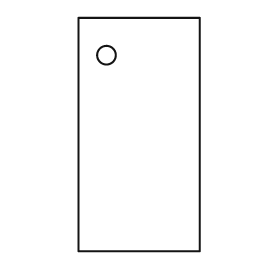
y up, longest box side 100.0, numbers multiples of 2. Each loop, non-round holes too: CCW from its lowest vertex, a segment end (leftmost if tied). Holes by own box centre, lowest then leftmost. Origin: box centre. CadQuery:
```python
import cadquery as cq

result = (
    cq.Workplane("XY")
    .moveTo(-26.0, -50.0)
    .lineTo(26.0, -50.0)
    .lineTo(26.0, 50.0)
    .lineTo(-26.0, 50.0)
    .close()
    .moveTo(-14.0, 34.0)
    .circle(4.0)
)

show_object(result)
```